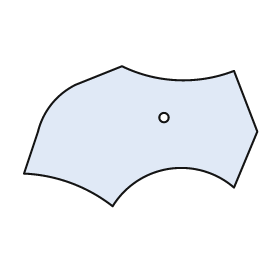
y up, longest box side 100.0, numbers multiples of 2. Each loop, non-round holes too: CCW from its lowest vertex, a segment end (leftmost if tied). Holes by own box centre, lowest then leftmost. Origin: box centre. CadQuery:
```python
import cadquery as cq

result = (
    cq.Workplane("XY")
    .moveTo(-12.0, -30.0)
    .threePointArc((12.0, -14.0), (40.0, -22.0))
    .lineTo(50.0, 2.0)
    .lineTo(40.0, 28.0)
    .threePointArc((16.0, 24.0), (-8.0, 30.0))
    .lineTo(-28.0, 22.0)
    .threePointArc((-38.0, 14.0), (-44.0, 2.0))
    .lineTo(-50.0, -16.0)
    .threePointArc((-30.0, -20.0), (-12.0, -30.0))
    .close()
    .moveTo(10.0, 8.0)
    .circle(2.0)
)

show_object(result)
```